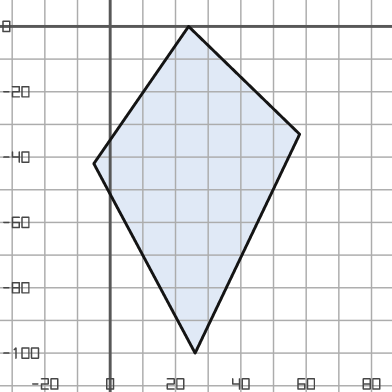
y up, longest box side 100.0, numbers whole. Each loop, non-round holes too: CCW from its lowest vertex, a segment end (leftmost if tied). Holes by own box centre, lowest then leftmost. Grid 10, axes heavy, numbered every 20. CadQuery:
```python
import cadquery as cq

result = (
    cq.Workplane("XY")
    .moveTo(26.0, -100.0)
    .lineTo(58.0, -33.0)
    .lineTo(24.0, 0.0)
    .lineTo(-5.0, -42.0)
    .close()
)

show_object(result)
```